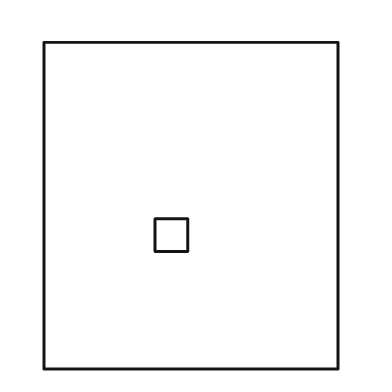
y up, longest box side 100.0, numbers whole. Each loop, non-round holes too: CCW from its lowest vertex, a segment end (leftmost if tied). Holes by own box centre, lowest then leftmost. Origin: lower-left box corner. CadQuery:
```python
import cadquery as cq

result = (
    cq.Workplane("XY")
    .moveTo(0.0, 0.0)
    .lineTo(90.0, 0.0)
    .lineTo(90.0, 100.0)
    .lineTo(0.0, 100.0)
    .close()
    .moveTo(34.0, 36.0)
    .lineTo(44.0, 36.0)
    .lineTo(44.0, 46.0)
    .lineTo(34.0, 46.0)
    .close()
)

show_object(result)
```